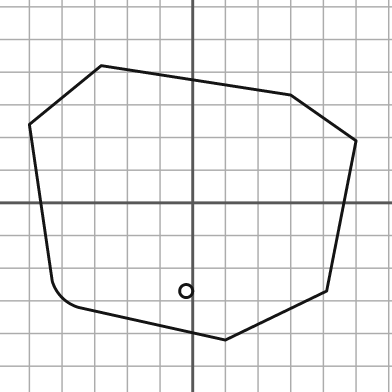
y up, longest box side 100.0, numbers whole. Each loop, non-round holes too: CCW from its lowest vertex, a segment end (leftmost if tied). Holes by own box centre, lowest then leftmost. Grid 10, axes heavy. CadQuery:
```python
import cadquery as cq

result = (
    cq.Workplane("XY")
    .moveTo(10.0, -42.0)
    .lineTo(41.0, -27.0)
    .lineTo(50.0, 19.0)
    .lineTo(30.0, 33.0)
    .lineTo(-28.0, 42.0)
    .lineTo(-50.0, 24.0)
    .lineTo(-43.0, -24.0)
    .threePointArc((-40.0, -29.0), (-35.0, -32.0))
    .close()
    .moveTo(-2.0, -27.0)
    .circle(2.0)
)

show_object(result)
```